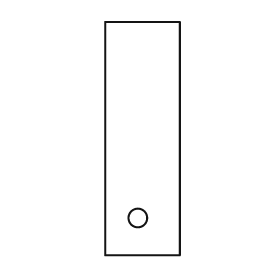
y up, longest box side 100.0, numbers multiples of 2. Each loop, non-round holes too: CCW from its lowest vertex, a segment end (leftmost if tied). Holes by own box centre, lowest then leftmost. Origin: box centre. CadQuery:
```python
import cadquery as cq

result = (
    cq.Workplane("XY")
    .moveTo(-16.0, -50.0)
    .lineTo(16.0, -50.0)
    .lineTo(16.0, 50.0)
    .lineTo(-16.0, 50.0)
    .close()
    .moveTo(-2.0, -34.0)
    .circle(4.0)
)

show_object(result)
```